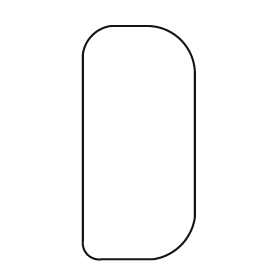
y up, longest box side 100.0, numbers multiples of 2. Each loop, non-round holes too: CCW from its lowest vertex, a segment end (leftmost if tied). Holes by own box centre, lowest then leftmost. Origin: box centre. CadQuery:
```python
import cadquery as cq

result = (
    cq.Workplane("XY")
    .moveTo(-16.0, -50.0)
    .lineTo(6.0, -50.0)
    .threePointArc((18.0, -44.0), (24.0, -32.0))
    .lineTo(24.0, 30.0)
    .threePointArc((18.0, 44.0), (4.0, 50.0))
    .lineTo(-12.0, 50.0)
    .threePointArc((-20.0, 46.0), (-24.0, 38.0))
    .lineTo(-24.0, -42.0)
    .threePointArc((-22.0, -48.0), (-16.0, -50.0))
    .close()
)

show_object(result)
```